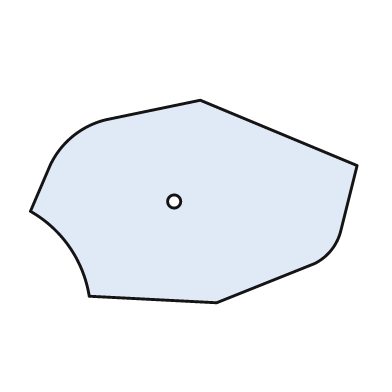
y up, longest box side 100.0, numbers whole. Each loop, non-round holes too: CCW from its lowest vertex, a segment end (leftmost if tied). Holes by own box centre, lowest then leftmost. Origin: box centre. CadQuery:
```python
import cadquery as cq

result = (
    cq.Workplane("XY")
    .moveTo(7.0, -31.0)
    .lineTo(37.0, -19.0)
    .threePointArc((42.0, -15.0), (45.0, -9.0))
    .lineTo(50.0, 11.0)
    .lineTo(2.0, 31.0)
    .lineTo(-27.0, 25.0)
    .threePointArc((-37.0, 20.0), (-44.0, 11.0))
    .lineTo(-50.0, -3.0)
    .threePointArc((-38.0, -14.0), (-32.0, -29.0))
    .close()
    .moveTo(-6.0, 0.0)
    .circle(2.0)
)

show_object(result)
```